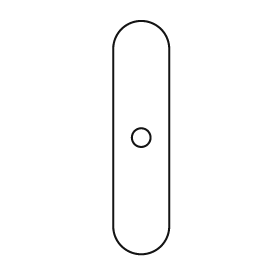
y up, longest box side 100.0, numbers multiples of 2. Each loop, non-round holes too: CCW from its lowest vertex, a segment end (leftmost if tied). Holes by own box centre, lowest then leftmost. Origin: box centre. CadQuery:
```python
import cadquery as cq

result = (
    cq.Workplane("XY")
    .moveTo(-12.0, -38.0)
    .threePointArc((0.0, -50.0), (12.0, -38.0))
    .lineTo(12.0, 38.0)
    .threePointArc((0.0, 50.0), (-12.0, 38.0))
    .close()
    .moveTo(0.0, 0.0)
    .circle(4.0)
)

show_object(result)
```